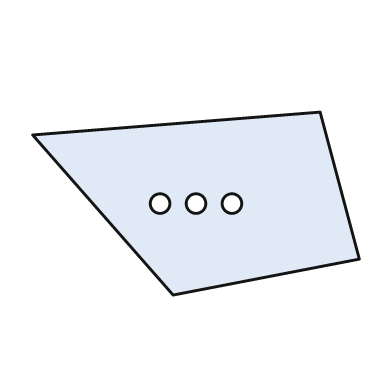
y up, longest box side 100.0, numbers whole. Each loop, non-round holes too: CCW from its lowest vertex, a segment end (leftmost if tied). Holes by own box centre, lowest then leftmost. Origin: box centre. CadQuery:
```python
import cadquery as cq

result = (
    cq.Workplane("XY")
    .moveTo(-7.0, -28.0)
    .lineTo(50.0, -17.0)
    .lineTo(38.0, 28.0)
    .lineTo(-50.0, 21.0)
    .close()
    .moveTo(-11.0, 0.0)
    .circle(3.0)
    .moveTo(0.0, 0.0)
    .circle(3.0)
    .moveTo(11.0, 0.0)
    .circle(3.0)
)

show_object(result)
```